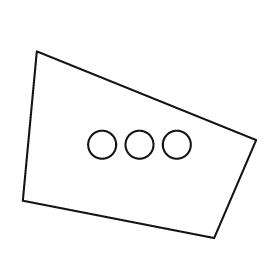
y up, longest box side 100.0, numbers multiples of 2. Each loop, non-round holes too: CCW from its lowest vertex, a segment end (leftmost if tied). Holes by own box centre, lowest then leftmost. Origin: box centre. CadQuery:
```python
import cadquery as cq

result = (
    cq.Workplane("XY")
    .moveTo(32.0, -40.0)
    .lineTo(50.0, 2.0)
    .lineTo(-44.0, 40.0)
    .lineTo(-50.0, -24.0)
    .close()
    .moveTo(-16.0, 0.0)
    .circle(6.0)
    .moveTo(0.0, 0.0)
    .circle(6.0)
    .moveTo(16.0, 0.0)
    .circle(6.0)
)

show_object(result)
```